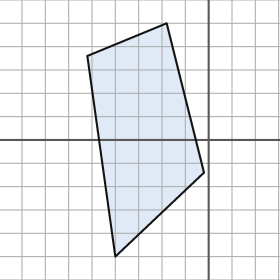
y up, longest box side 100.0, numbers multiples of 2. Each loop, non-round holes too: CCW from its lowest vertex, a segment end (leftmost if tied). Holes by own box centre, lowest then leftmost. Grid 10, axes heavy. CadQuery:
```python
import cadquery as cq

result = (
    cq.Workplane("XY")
    .moveTo(-40.0, -50.0)
    .lineTo(-2.0, -14.0)
    .lineTo(-18.0, 50.0)
    .lineTo(-52.0, 36.0)
    .close()
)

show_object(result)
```